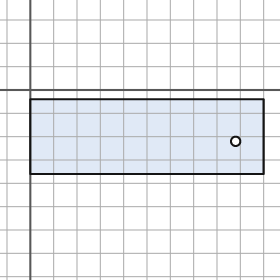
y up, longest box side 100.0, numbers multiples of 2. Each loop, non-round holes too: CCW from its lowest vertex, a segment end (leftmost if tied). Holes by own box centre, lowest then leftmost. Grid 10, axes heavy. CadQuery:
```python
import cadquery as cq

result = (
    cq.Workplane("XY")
    .moveTo(0.0, -36.0)
    .lineTo(100.0, -36.0)
    .lineTo(100.0, -4.0)
    .lineTo(0.0, -4.0)
    .close()
    .moveTo(88.0, -22.0)
    .circle(2.0)
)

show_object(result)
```